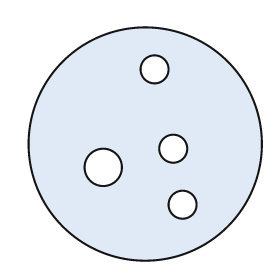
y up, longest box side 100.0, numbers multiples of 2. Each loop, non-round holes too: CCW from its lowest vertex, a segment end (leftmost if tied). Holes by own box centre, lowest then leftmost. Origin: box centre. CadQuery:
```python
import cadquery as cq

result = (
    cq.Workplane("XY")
    .moveTo(0.0, 0.0)
    .circle(50.0)
    .moveTo(16.0, -26.0)
    .circle(6.0)
    .moveTo(-18.0, -10.0)
    .circle(8.0)
    .moveTo(12.0, -2.0)
    .circle(6.0)
    .moveTo(4.0, 32.0)
    .circle(6.0)
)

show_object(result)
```